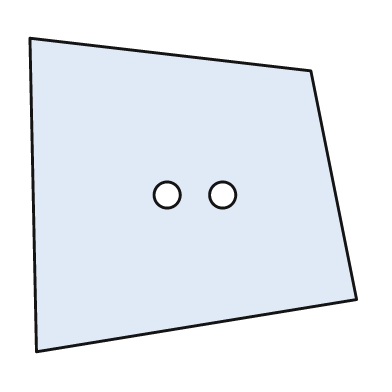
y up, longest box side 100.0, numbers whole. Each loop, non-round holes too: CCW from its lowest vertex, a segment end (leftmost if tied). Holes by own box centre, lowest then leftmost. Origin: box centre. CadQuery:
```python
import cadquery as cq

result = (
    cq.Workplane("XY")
    .moveTo(-48.0, -48.0)
    .lineTo(50.0, -32.0)
    .lineTo(36.0, 38.0)
    .lineTo(-50.0, 48.0)
    .close()
    .moveTo(-8.0, 0.0)
    .circle(4.0)
    .moveTo(9.0, 0.0)
    .circle(4.0)
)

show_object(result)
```